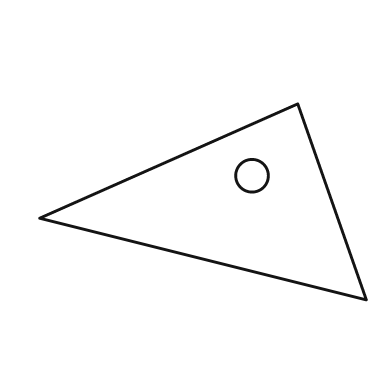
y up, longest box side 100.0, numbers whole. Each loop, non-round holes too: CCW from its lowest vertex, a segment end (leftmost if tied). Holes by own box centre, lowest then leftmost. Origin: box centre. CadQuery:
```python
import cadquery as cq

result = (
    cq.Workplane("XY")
    .moveTo(50.0, -30.0)
    .lineTo(29.0, 30.0)
    .lineTo(-50.0, -5.0)
    .close()
    .moveTo(15.0, 8.0)
    .circle(5.0)
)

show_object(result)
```